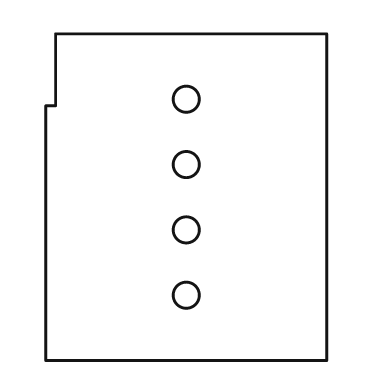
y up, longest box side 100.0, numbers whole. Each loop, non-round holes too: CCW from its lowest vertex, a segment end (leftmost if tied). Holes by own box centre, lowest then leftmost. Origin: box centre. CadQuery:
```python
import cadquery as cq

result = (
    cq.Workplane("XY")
    .moveTo(-43.0, -50.0)
    .lineTo(43.0, -50.0)
    .lineTo(43.0, 50.0)
    .lineTo(-40.0, 50.0)
    .lineTo(-40.0, 28.0)
    .lineTo(-43.0, 28.0)
    .close()
    .moveTo(0.0, -30.0)
    .circle(4.0)
    .moveTo(0.0, -10.0)
    .circle(4.0)
    .moveTo(0.0, 10.0)
    .circle(4.0)
    .moveTo(0.0, 30.0)
    .circle(4.0)
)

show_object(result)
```